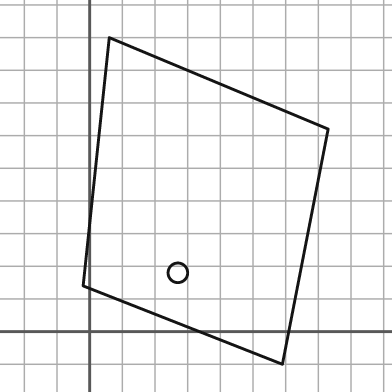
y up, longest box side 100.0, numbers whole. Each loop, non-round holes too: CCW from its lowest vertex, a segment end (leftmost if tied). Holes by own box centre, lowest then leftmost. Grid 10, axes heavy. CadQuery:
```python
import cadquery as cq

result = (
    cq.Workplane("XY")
    .moveTo(59.0, -10.0)
    .lineTo(73.0, 62.0)
    .lineTo(6.0, 90.0)
    .lineTo(-2.0, 14.0)
    .close()
    .moveTo(27.0, 18.0)
    .circle(3.0)
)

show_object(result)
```